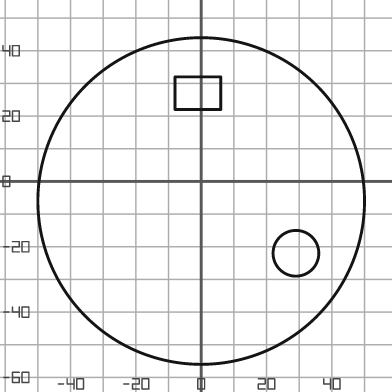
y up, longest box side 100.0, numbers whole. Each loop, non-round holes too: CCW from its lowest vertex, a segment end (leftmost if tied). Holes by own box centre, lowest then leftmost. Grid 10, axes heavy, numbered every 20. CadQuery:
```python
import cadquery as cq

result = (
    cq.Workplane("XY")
    .moveTo(0.0, -6.0)
    .circle(50.0)
    .moveTo(29.0, -22.0)
    .circle(7.0)
    .moveTo(-8.0, 22.0)
    .lineTo(6.0, 22.0)
    .lineTo(6.0, 32.0)
    .lineTo(-8.0, 32.0)
    .close()
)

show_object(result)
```